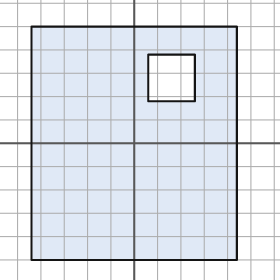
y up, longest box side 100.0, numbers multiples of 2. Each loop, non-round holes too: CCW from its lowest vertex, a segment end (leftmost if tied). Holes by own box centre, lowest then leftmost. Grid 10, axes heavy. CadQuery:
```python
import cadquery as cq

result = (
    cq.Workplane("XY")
    .moveTo(-44.0, -50.0)
    .lineTo(44.0, -50.0)
    .lineTo(44.0, 50.0)
    .lineTo(-44.0, 50.0)
    .close()
    .moveTo(6.0, 18.0)
    .lineTo(26.0, 18.0)
    .lineTo(26.0, 38.0)
    .lineTo(6.0, 38.0)
    .close()
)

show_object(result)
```